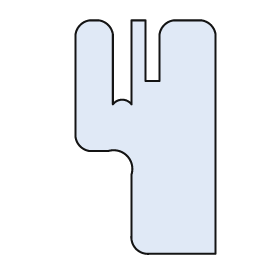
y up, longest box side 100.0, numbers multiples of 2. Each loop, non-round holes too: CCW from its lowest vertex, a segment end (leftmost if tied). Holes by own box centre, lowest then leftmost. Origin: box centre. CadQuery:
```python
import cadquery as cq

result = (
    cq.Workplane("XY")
    .moveTo(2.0, -50.0)
    .lineTo(30.0, -50.0)
    .lineTo(30.0, 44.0)
    .threePointArc((28.0, 48.0), (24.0, 50.0))
    .lineTo(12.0, 50.0)
    .threePointArc((8.0, 48.0), (6.0, 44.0))
    .lineTo(6.0, 24.0)
    .lineTo(0.0, 24.0)
    .lineTo(0.0, 50.0)
    .lineTo(-6.0, 50.0)
    .lineTo(-6.0, 14.0)
    .threePointArc((-10.0, 16.0), (-14.0, 14.0))
    .lineTo(-14.0, 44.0)
    .threePointArc((-16.0, 48.0), (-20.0, 50.0))
    .lineTo(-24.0, 50.0)
    .threePointArc((-28.0, 48.0), (-30.0, 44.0))
    .lineTo(-30.0, 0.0)
    .threePointArc((-28.0, -4.0), (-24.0, -6.0))
    .lineTo(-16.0, -6.0)
    .threePointArc((-8.0, -8.0), (-6.0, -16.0))
    .lineTo(-6.0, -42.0)
    .threePointArc((-4.0, -48.0), (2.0, -50.0))
    .close()
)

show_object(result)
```